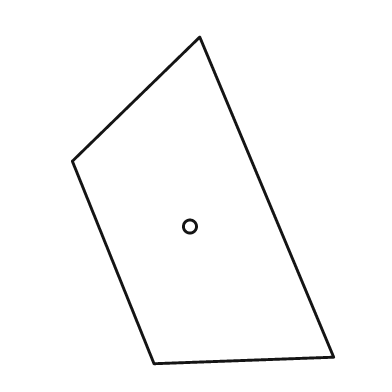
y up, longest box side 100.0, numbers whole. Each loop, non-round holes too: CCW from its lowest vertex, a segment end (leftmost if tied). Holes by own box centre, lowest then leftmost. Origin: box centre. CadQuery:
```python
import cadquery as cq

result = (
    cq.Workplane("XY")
    .moveTo(-15.0, -50.0)
    .lineTo(40.0, -48.0)
    .lineTo(-1.0, 50.0)
    .lineTo(-40.0, 12.0)
    .close()
    .moveTo(-4.0, -8.0)
    .circle(2.0)
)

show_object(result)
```